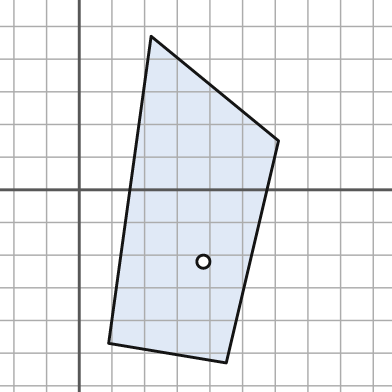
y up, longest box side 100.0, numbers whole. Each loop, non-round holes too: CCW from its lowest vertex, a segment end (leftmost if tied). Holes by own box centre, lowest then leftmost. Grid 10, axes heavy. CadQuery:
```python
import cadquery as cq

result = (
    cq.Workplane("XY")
    .moveTo(45.0, -53.0)
    .lineTo(61.0, 15.0)
    .lineTo(22.0, 47.0)
    .lineTo(9.0, -47.0)
    .close()
    .moveTo(38.0, -22.0)
    .circle(2.0)
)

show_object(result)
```